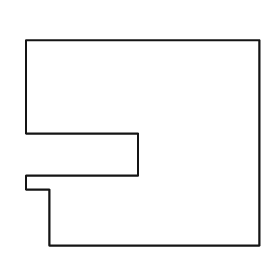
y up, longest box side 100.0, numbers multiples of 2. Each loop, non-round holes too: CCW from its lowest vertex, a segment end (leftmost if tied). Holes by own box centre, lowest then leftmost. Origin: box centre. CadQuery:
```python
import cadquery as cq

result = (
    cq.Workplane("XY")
    .moveTo(-40.0, -44.0)
    .lineTo(50.0, -44.0)
    .lineTo(50.0, 44.0)
    .lineTo(-50.0, 44.0)
    .lineTo(-50.0, 4.0)
    .lineTo(-2.0, 4.0)
    .lineTo(-2.0, -14.0)
    .lineTo(-50.0, -14.0)
    .lineTo(-50.0, -20.0)
    .lineTo(-40.0, -20.0)
    .close()
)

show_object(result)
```